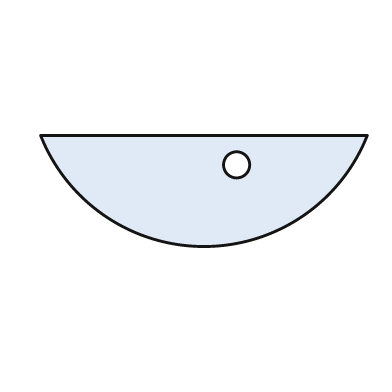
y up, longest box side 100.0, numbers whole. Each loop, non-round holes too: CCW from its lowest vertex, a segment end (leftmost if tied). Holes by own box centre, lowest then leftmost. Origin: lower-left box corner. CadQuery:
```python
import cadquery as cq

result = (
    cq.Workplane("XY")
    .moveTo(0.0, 34.0)
    .threePointArc((50.0, 0.0), (100.0, 34.0))
    .close()
    .moveTo(60.0, 25.0)
    .circle(4.0)
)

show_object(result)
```